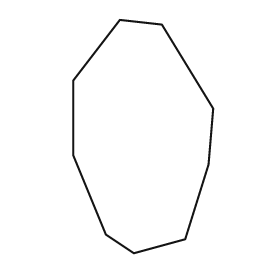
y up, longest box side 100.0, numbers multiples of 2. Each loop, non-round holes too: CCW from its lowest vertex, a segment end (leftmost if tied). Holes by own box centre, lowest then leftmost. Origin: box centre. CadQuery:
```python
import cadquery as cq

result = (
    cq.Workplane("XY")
    .moveTo(-4.0, -50.0)
    .lineTo(18.0, -44.0)
    .lineTo(28.0, -12.0)
    .lineTo(30.0, 12.0)
    .lineTo(8.0, 48.0)
    .lineTo(-10.0, 50.0)
    .lineTo(-30.0, 24.0)
    .lineTo(-30.0, -8.0)
    .lineTo(-16.0, -42.0)
    .close()
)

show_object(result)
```